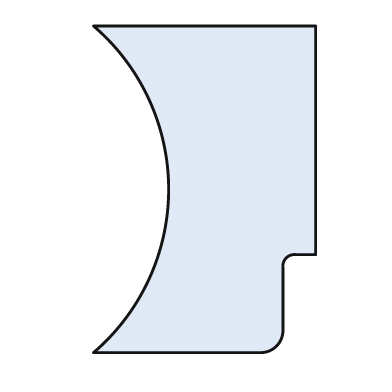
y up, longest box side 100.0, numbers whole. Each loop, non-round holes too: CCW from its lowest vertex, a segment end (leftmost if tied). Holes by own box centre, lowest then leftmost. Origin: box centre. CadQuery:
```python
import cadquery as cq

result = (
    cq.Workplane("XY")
    .moveTo(-34.0, -50.0)
    .lineTo(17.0, -50.0)
    .threePointArc((22.0, -48.0), (24.0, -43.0))
    .lineTo(24.0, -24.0)
    .threePointArc((25.0, -21.0), (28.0, -20.0))
    .lineTo(34.0, -20.0)
    .lineTo(34.0, 50.0)
    .lineTo(-34.0, 50.0)
    .threePointArc((-11.0, 0.0), (-34.0, -50.0))
    .close()
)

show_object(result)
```